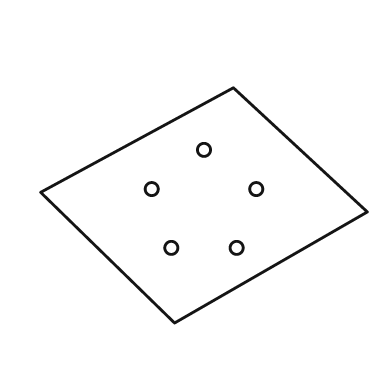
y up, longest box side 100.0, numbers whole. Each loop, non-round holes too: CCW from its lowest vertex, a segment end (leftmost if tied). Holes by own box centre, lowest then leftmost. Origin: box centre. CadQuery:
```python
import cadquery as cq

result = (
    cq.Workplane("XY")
    .moveTo(-9.0, -36.0)
    .lineTo(50.0, -2.0)
    .lineTo(9.0, 36.0)
    .lineTo(-50.0, 4.0)
    .close()
    .moveTo(-10.0, -13.0)
    .circle(2.0)
    .moveTo(10.0, -13.0)
    .circle(2.0)
    .moveTo(-16.0, 5.0)
    .circle(2.0)
    .moveTo(16.0, 5.0)
    .circle(2.0)
    .moveTo(0.0, 17.0)
    .circle(2.0)
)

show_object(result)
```